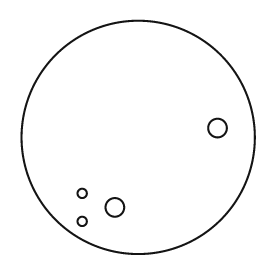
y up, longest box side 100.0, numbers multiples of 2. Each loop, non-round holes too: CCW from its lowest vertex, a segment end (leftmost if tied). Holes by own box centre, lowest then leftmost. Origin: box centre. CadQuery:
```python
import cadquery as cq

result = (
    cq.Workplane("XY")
    .moveTo(0.0, 0.0)
    .circle(50.0)
    .moveTo(-24.0, -36.0)
    .circle(2.0)
    .moveTo(-10.0, -30.0)
    .circle(4.0)
    .moveTo(-24.0, -24.0)
    .circle(2.0)
    .moveTo(34.0, 4.0)
    .circle(4.0)
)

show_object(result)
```